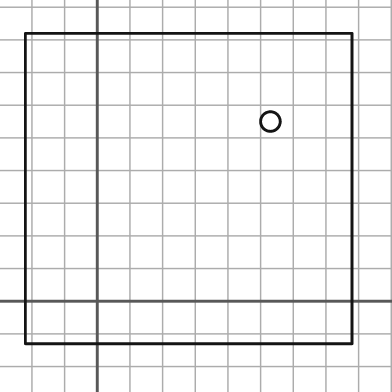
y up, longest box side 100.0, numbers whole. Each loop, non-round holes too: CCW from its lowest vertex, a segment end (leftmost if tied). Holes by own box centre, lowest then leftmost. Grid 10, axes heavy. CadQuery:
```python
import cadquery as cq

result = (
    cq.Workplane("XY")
    .moveTo(-22.0, -13.0)
    .lineTo(78.0, -13.0)
    .lineTo(78.0, 82.0)
    .lineTo(-22.0, 82.0)
    .close()
    .moveTo(53.0, 55.0)
    .circle(3.0)
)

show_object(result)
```